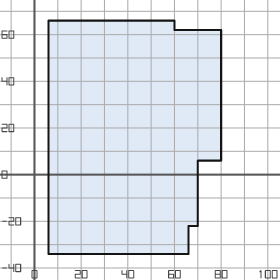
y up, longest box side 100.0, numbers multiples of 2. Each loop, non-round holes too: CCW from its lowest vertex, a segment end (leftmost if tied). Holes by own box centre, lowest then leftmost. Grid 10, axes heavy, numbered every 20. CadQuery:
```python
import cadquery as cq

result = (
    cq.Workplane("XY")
    .moveTo(6.0, -34.0)
    .lineTo(66.0, -34.0)
    .lineTo(66.0, -22.0)
    .lineTo(70.0, -22.0)
    .lineTo(70.0, 6.0)
    .lineTo(80.0, 6.0)
    .lineTo(80.0, 62.0)
    .lineTo(60.0, 62.0)
    .lineTo(60.0, 66.0)
    .lineTo(6.0, 66.0)
    .close()
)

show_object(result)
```